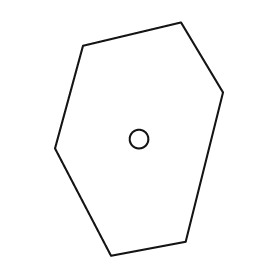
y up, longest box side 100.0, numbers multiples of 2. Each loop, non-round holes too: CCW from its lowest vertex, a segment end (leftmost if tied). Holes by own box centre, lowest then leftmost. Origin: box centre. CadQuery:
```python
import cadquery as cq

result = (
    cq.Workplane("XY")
    .moveTo(-12.0, -50.0)
    .lineTo(20.0, -44.0)
    .lineTo(36.0, 20.0)
    .lineTo(18.0, 50.0)
    .lineTo(-24.0, 40.0)
    .lineTo(-36.0, -4.0)
    .close()
    .moveTo(0.0, 0.0)
    .circle(4.0)
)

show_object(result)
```